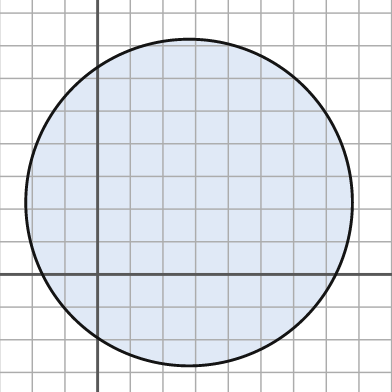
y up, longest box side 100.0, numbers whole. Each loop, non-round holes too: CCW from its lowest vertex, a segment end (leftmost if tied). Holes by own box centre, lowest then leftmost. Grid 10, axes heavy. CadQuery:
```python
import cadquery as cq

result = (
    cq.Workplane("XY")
    .moveTo(28.0, 22.0)
    .circle(50.0)
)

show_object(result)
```